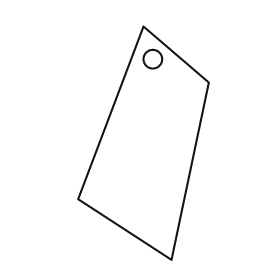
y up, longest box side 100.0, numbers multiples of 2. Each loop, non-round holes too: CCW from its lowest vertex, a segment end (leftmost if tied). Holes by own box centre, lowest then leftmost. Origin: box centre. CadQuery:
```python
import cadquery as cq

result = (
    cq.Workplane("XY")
    .moveTo(12.0, -50.0)
    .lineTo(28.0, 26.0)
    .lineTo(0.0, 50.0)
    .lineTo(-28.0, -24.0)
    .close()
    .moveTo(4.0, 36.0)
    .circle(4.0)
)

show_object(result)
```